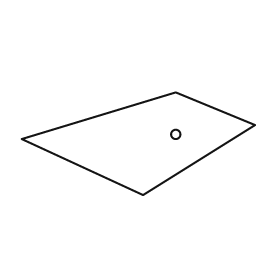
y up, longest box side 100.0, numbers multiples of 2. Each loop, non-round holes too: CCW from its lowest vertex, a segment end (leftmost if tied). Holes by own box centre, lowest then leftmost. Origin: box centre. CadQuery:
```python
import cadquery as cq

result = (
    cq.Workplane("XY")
    .moveTo(2.0, -22.0)
    .lineTo(50.0, 8.0)
    .lineTo(16.0, 22.0)
    .lineTo(-50.0, 2.0)
    .close()
    .moveTo(16.0, 4.0)
    .circle(2.0)
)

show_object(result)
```